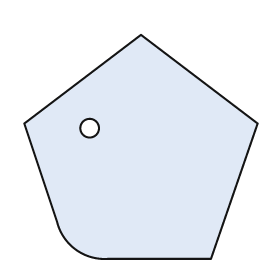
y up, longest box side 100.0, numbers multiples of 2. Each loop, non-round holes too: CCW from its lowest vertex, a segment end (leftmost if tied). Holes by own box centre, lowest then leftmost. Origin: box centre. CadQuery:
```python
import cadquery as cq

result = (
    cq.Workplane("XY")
    .moveTo(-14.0, -48.0)
    .lineTo(30.0, -48.0)
    .lineTo(50.0, 10.0)
    .lineTo(0.0, 48.0)
    .lineTo(-50.0, 10.0)
    .lineTo(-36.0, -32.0)
    .threePointArc((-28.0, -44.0), (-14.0, -48.0))
    .close()
    .moveTo(-22.0, 8.0)
    .circle(4.0)
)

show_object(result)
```